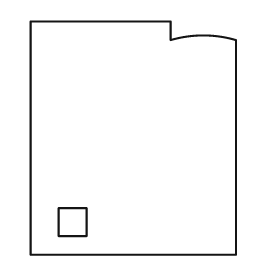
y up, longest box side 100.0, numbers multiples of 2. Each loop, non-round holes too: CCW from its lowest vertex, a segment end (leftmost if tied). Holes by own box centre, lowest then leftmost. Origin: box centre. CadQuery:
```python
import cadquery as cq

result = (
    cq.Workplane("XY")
    .moveTo(-44.0, -50.0)
    .lineTo(44.0, -50.0)
    .lineTo(44.0, 42.0)
    .threePointArc((30.0, 44.0), (16.0, 42.0))
    .lineTo(16.0, 50.0)
    .lineTo(-44.0, 50.0)
    .close()
    .moveTo(-32.0, -42.0)
    .lineTo(-20.0, -42.0)
    .lineTo(-20.0, -30.0)
    .lineTo(-32.0, -30.0)
    .close()
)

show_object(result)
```